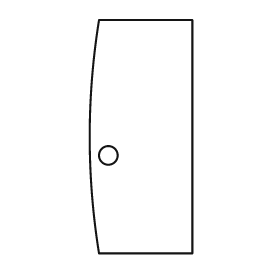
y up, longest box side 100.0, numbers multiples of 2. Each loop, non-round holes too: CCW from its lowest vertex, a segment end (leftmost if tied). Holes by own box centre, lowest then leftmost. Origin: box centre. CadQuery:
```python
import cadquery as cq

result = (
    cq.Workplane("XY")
    .moveTo(-18.0, -50.0)
    .lineTo(22.0, -50.0)
    .lineTo(22.0, 50.0)
    .lineTo(-18.0, 50.0)
    .threePointArc((-22.0, 0.0), (-18.0, -50.0))
    .close()
    .moveTo(-14.0, -8.0)
    .circle(4.0)
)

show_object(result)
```